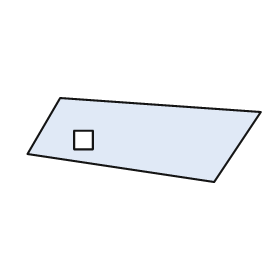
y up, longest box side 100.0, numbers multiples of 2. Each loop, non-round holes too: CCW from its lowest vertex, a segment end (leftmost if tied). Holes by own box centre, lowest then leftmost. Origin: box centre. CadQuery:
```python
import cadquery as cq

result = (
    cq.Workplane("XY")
    .moveTo(30.0, -18.0)
    .lineTo(50.0, 12.0)
    .lineTo(-36.0, 18.0)
    .lineTo(-50.0, -6.0)
    .close()
    .moveTo(-30.0, -4.0)
    .lineTo(-22.0, -4.0)
    .lineTo(-22.0, 4.0)
    .lineTo(-30.0, 4.0)
    .close()
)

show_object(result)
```